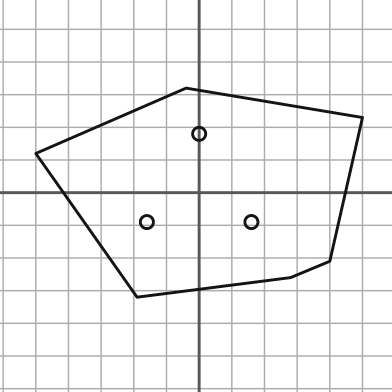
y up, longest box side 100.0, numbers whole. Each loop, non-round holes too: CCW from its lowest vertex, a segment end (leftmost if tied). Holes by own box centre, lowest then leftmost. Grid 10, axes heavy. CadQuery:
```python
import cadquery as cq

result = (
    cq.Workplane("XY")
    .moveTo(-19.0, -32.0)
    .lineTo(28.0, -26.0)
    .lineTo(40.0, -21.0)
    .lineTo(50.0, 23.0)
    .lineTo(-4.0, 32.0)
    .lineTo(-50.0, 12.0)
    .close()
    .moveTo(-16.0, -9.0)
    .circle(2.0)
    .moveTo(16.0, -9.0)
    .circle(2.0)
    .moveTo(0.0, 18.0)
    .circle(2.0)
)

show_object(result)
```